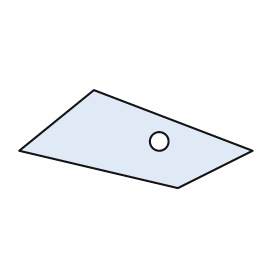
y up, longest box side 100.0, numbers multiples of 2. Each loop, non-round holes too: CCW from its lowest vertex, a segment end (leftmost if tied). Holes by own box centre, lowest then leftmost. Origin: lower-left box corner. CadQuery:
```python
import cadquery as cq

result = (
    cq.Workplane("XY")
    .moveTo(68.0, 0.0)
    .lineTo(100.0, 16.0)
    .lineTo(32.0, 42.0)
    .lineTo(0.0, 16.0)
    .close()
    .moveTo(60.0, 20.0)
    .circle(4.0)
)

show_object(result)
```